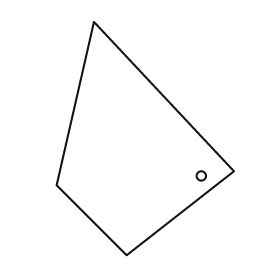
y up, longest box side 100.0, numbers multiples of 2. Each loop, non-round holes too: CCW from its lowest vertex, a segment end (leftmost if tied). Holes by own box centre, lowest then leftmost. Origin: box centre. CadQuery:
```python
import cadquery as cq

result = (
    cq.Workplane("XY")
    .moveTo(-8.0, -50.0)
    .lineTo(38.0, -14.0)
    .lineTo(-22.0, 50.0)
    .lineTo(-38.0, -20.0)
    .close()
    .moveTo(24.0, -16.0)
    .circle(2.0)
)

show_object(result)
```